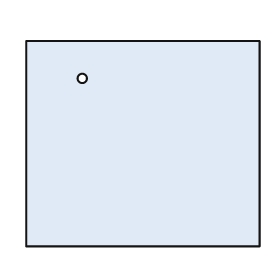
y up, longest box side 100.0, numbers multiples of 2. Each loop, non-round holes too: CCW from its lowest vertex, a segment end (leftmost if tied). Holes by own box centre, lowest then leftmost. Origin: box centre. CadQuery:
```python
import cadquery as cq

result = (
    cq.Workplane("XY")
    .moveTo(-50.0, -44.0)
    .lineTo(50.0, -44.0)
    .lineTo(50.0, 44.0)
    .lineTo(-50.0, 44.0)
    .close()
    .moveTo(-26.0, 28.0)
    .circle(2.0)
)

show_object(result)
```